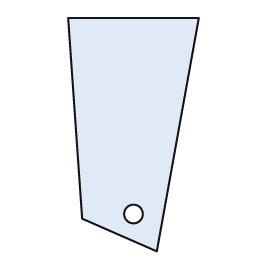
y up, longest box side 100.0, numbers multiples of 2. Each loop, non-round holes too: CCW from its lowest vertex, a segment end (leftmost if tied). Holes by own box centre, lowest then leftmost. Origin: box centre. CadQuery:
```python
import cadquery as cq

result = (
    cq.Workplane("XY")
    .moveTo(10.0, -50.0)
    .lineTo(28.0, 50.0)
    .lineTo(-28.0, 50.0)
    .lineTo(-22.0, -36.0)
    .close()
    .moveTo(0.0, -34.0)
    .circle(4.0)
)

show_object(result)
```